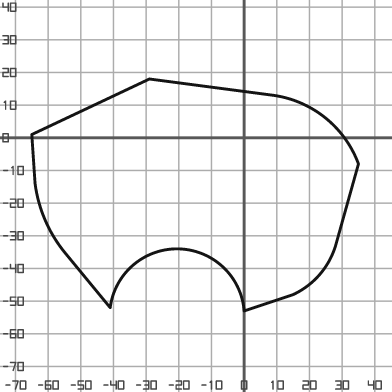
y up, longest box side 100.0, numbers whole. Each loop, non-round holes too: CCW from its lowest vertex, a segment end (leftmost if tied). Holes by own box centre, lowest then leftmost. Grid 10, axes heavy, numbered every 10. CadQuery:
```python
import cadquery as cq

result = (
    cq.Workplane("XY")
    .moveTo(0.0, -53.0)
    .lineTo(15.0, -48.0)
    .threePointArc((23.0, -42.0), (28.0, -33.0))
    .lineTo(35.0, -8.0)
    .threePointArc((25.0, 6.0), (9.0, 13.0))
    .lineTo(-29.0, 18.0)
    .lineTo(-65.0, 1.0)
    .lineTo(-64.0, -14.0)
    .threePointArc((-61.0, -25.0), (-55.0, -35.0))
    .lineTo(-41.0, -52.0)
    .threePointArc((-20.0, -34.0), (0.0, -53.0))
    .close()
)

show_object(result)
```